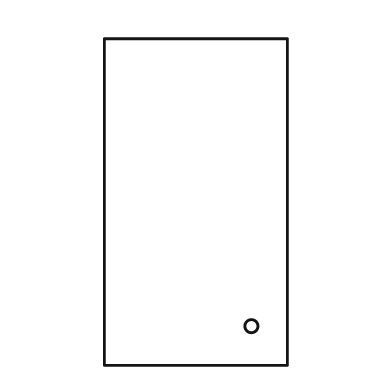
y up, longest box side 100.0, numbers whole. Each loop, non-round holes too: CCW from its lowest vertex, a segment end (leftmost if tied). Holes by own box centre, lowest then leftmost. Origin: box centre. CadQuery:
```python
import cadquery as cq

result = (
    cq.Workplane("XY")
    .moveTo(-28.0, -50.0)
    .lineTo(28.0, -50.0)
    .lineTo(28.0, 50.0)
    .lineTo(-28.0, 50.0)
    .close()
    .moveTo(17.0, -38.0)
    .circle(2.0)
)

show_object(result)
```